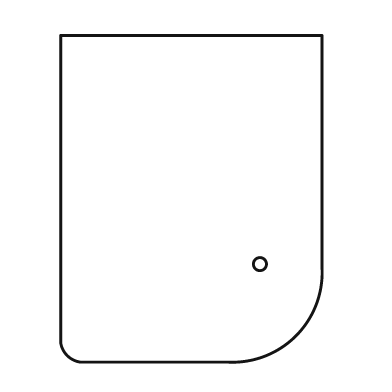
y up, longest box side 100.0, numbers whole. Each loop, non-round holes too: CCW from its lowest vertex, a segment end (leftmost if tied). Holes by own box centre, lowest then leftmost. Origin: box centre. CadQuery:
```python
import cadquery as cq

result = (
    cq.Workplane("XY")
    .moveTo(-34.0, -50.0)
    .lineTo(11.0, -50.0)
    .threePointArc((32.0, -42.0), (40.0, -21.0))
    .lineTo(40.0, 50.0)
    .lineTo(-40.0, 50.0)
    .lineTo(-40.0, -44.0)
    .threePointArc((-38.0, -48.0), (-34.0, -50.0))
    .close()
    .moveTo(21.0, -20.0)
    .circle(2.0)
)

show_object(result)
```